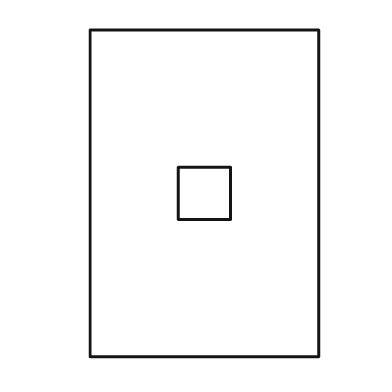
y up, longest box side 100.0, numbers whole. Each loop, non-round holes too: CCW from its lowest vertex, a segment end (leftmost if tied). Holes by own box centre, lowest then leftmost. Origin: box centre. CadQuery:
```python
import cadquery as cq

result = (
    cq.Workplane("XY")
    .moveTo(-35.0, -50.0)
    .lineTo(35.0, -50.0)
    .lineTo(35.0, 50.0)
    .lineTo(-35.0, 50.0)
    .close()
    .moveTo(-8.0, -8.0)
    .lineTo(8.0, -8.0)
    .lineTo(8.0, 8.0)
    .lineTo(-8.0, 8.0)
    .close()
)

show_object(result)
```